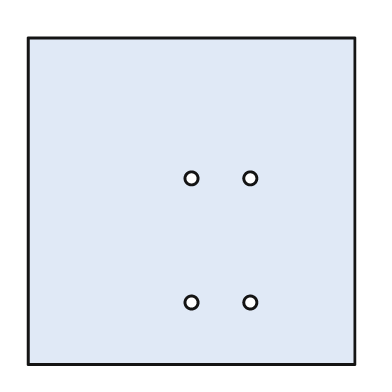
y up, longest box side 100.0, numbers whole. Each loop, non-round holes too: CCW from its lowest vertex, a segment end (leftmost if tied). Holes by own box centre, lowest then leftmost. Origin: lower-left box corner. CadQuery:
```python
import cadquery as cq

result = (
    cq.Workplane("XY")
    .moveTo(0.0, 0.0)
    .lineTo(100.0, 0.0)
    .lineTo(100.0, 100.0)
    .lineTo(0.0, 100.0)
    .close()
    .moveTo(50.0, 19.0)
    .circle(2.0)
    .moveTo(68.0, 19.0)
    .circle(2.0)
    .moveTo(50.0, 57.0)
    .circle(2.0)
    .moveTo(68.0, 57.0)
    .circle(2.0)
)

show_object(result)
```